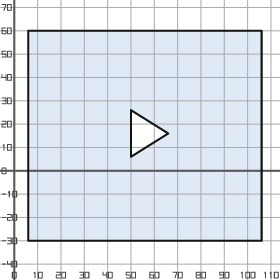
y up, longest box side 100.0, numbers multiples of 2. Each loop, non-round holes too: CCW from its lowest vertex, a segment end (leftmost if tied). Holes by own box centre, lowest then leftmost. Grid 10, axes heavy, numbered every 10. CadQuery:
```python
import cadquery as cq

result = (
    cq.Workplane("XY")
    .moveTo(6.0, -30.0)
    .lineTo(106.0, -30.0)
    .lineTo(106.0, 60.0)
    .lineTo(6.0, 60.0)
    .close()
    .moveTo(50.0, 6.0)
    .lineTo(66.0, 16.0)
    .lineTo(50.0, 26.0)
    .close()
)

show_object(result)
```